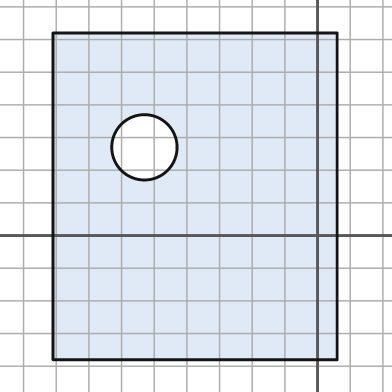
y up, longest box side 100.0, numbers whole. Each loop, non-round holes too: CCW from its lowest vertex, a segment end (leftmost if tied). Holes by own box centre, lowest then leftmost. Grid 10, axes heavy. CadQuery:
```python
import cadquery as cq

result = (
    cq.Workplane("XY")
    .moveTo(-81.0, -38.0)
    .lineTo(6.0, -38.0)
    .lineTo(6.0, 62.0)
    .lineTo(-81.0, 62.0)
    .close()
    .moveTo(-53.0, 27.0)
    .circle(10.0)
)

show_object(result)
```